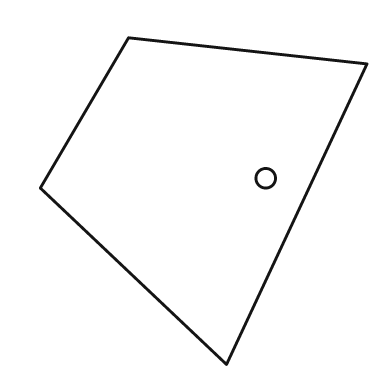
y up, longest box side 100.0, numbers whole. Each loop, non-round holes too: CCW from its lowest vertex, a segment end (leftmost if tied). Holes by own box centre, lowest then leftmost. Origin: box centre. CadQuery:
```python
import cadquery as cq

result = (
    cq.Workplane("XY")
    .moveTo(7.0, -50.0)
    .lineTo(50.0, 42.0)
    .lineTo(-23.0, 50.0)
    .lineTo(-50.0, 4.0)
    .close()
    .moveTo(19.0, 7.0)
    .circle(3.0)
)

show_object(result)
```